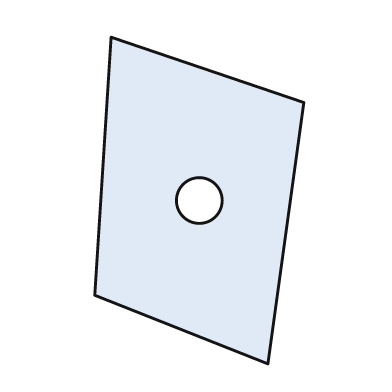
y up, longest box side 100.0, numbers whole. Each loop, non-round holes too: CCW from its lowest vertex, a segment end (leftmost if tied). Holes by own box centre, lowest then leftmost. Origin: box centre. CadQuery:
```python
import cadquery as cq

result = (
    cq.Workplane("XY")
    .moveTo(21.0, -50.0)
    .lineTo(32.0, 30.0)
    .lineTo(-27.0, 50.0)
    .lineTo(-32.0, -29.0)
    .close()
    .moveTo(0.0, 0.0)
    .circle(7.0)
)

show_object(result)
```